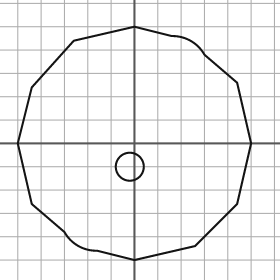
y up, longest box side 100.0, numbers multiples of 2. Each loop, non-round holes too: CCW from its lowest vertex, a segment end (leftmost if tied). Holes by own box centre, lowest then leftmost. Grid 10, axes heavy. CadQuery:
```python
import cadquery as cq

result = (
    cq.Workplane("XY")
    .moveTo(0.0, -50.0)
    .lineTo(26.0, -44.0)
    .lineTo(44.0, -26.0)
    .lineTo(50.0, 0.0)
    .lineTo(44.0, 26.0)
    .lineTo(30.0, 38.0)
    .threePointArc((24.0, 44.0), (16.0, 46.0))
    .lineTo(0.0, 50.0)
    .lineTo(-26.0, 44.0)
    .lineTo(-44.0, 24.0)
    .lineTo(-50.0, 0.0)
    .lineTo(-44.0, -26.0)
    .lineTo(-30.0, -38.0)
    .threePointArc((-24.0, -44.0), (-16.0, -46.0))
    .close()
    .moveTo(-2.0, -10.0)
    .circle(6.0)
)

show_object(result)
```